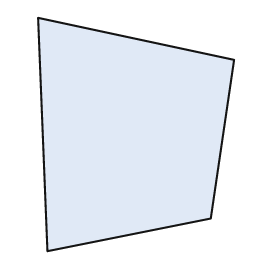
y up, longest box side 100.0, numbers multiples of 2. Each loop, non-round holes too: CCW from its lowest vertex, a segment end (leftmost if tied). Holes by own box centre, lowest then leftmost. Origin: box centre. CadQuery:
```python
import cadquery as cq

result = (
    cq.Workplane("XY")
    .moveTo(-38.0, -50.0)
    .lineTo(32.0, -36.0)
    .lineTo(42.0, 32.0)
    .lineTo(-42.0, 50.0)
    .close()
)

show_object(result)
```